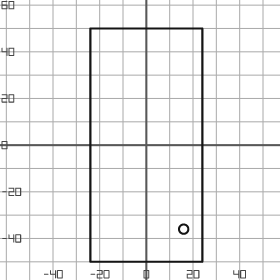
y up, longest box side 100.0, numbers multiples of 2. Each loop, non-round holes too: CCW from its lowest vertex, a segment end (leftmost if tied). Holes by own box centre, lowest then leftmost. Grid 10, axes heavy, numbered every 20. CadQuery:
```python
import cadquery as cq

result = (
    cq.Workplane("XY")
    .moveTo(-24.0, -50.0)
    .lineTo(24.0, -50.0)
    .lineTo(24.0, 50.0)
    .lineTo(-24.0, 50.0)
    .close()
    .moveTo(16.0, -36.0)
    .circle(2.0)
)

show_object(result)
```